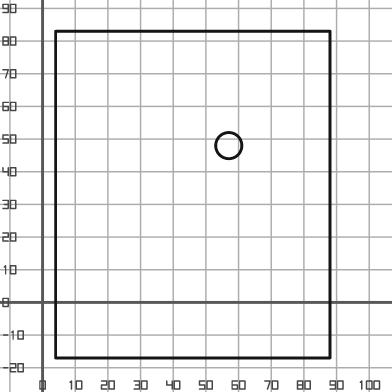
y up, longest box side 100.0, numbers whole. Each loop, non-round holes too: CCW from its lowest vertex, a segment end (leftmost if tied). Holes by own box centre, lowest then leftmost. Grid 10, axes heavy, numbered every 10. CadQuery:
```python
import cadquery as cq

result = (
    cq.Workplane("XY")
    .moveTo(4.0, -17.0)
    .lineTo(88.0, -17.0)
    .lineTo(88.0, 83.0)
    .lineTo(4.0, 83.0)
    .close()
    .moveTo(57.0, 48.0)
    .circle(4.0)
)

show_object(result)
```